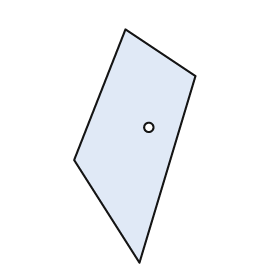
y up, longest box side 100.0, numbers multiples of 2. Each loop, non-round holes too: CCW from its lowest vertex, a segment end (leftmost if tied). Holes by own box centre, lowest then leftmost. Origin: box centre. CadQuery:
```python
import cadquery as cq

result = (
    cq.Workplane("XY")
    .moveTo(2.0, -50.0)
    .lineTo(26.0, 30.0)
    .lineTo(-4.0, 50.0)
    .lineTo(-26.0, -6.0)
    .close()
    .moveTo(6.0, 8.0)
    .circle(2.0)
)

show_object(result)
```